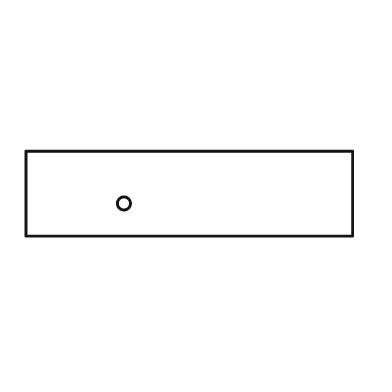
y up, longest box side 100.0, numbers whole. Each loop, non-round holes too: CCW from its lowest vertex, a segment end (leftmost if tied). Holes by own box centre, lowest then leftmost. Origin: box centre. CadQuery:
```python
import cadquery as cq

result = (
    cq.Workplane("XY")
    .moveTo(-50.0, -13.0)
    .lineTo(50.0, -13.0)
    .lineTo(50.0, 13.0)
    .lineTo(-50.0, 13.0)
    .close()
    .moveTo(-20.0, -3.0)
    .circle(2.0)
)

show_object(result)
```